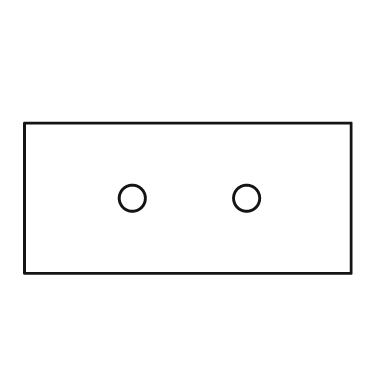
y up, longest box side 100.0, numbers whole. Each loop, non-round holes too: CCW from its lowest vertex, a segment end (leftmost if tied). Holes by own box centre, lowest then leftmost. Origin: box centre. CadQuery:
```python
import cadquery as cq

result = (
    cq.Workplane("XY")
    .moveTo(-50.0, -23.0)
    .lineTo(50.0, -23.0)
    .lineTo(50.0, 23.0)
    .lineTo(-50.0, 23.0)
    .close()
    .moveTo(-17.0, 0.0)
    .circle(4.0)
    .moveTo(18.0, 0.0)
    .circle(4.0)
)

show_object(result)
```